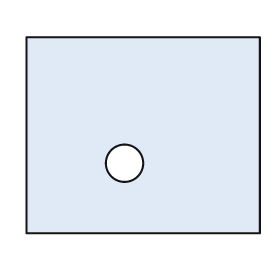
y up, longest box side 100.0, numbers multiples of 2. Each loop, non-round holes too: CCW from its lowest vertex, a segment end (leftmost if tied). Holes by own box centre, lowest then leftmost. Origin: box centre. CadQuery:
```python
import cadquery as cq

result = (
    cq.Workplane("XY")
    .moveTo(-50.0, -42.0)
    .lineTo(50.0, -42.0)
    .lineTo(50.0, 42.0)
    .lineTo(-50.0, 42.0)
    .close()
    .moveTo(-8.0, -12.0)
    .circle(8.0)
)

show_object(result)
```